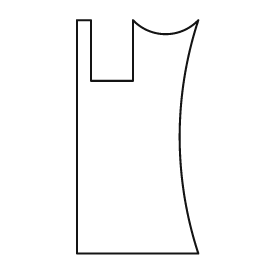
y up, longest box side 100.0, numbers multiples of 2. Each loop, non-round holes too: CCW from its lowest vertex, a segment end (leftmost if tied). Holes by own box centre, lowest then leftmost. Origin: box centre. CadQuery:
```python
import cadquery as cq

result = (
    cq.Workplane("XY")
    .moveTo(-26.0, -50.0)
    .lineTo(26.0, -50.0)
    .threePointArc((18.0, 0.0), (26.0, 50.0))
    .threePointArc((12.0, 44.0), (-2.0, 50.0))
    .lineTo(-2.0, 24.0)
    .lineTo(-20.0, 24.0)
    .lineTo(-20.0, 50.0)
    .lineTo(-26.0, 50.0)
    .close()
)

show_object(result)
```